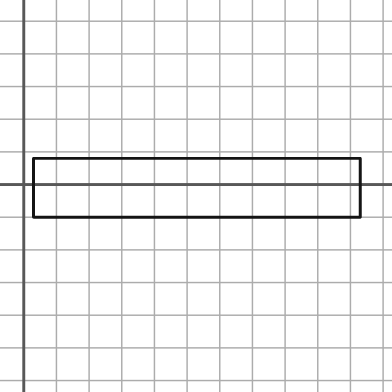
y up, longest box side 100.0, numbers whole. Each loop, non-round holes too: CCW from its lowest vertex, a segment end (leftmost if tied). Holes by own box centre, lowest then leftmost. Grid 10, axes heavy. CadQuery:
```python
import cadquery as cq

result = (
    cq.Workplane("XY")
    .moveTo(3.0, -10.0)
    .lineTo(103.0, -10.0)
    .lineTo(103.0, 8.0)
    .lineTo(3.0, 8.0)
    .close()
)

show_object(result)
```